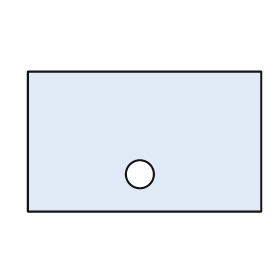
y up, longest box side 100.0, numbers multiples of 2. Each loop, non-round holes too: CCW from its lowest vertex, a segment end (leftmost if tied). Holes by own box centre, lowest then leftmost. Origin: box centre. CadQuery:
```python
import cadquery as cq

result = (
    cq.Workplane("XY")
    .moveTo(-50.0, -30.0)
    .lineTo(50.0, -30.0)
    .lineTo(50.0, 30.0)
    .lineTo(-50.0, 30.0)
    .close()
    .moveTo(-2.0, -14.0)
    .circle(6.0)
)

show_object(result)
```